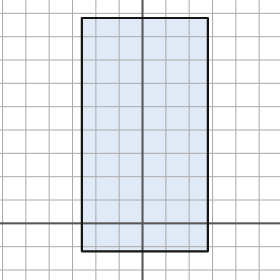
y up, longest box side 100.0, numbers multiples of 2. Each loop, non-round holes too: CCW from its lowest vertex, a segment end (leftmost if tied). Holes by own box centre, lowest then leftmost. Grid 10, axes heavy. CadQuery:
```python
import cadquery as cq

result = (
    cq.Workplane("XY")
    .moveTo(-26.0, -12.0)
    .lineTo(28.0, -12.0)
    .lineTo(28.0, 88.0)
    .lineTo(-26.0, 88.0)
    .close()
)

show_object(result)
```